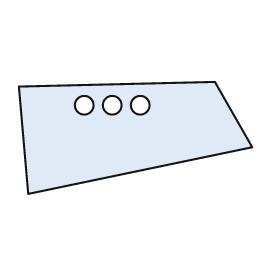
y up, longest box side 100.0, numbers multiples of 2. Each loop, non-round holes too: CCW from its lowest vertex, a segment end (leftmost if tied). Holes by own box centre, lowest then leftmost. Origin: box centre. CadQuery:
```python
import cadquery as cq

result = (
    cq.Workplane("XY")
    .moveTo(-46.0, -24.0)
    .lineTo(50.0, -4.0)
    .lineTo(34.0, 24.0)
    .lineTo(-50.0, 22.0)
    .close()
    .moveTo(-22.0, 14.0)
    .circle(4.0)
    .moveTo(-10.0, 14.0)
    .circle(4.0)
    .moveTo(2.0, 14.0)
    .circle(4.0)
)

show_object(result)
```